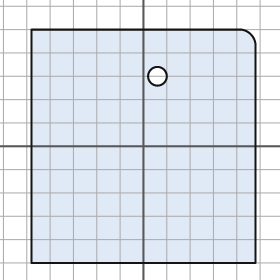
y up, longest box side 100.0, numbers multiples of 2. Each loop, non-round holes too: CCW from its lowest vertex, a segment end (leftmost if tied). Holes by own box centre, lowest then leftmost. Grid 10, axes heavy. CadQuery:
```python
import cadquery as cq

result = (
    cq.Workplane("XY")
    .moveTo(-48.0, -50.0)
    .lineTo(48.0, -50.0)
    .lineTo(48.0, 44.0)
    .threePointArc((46.0, 48.0), (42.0, 50.0))
    .lineTo(-48.0, 50.0)
    .close()
    .moveTo(6.0, 30.0)
    .circle(4.0)
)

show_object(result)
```